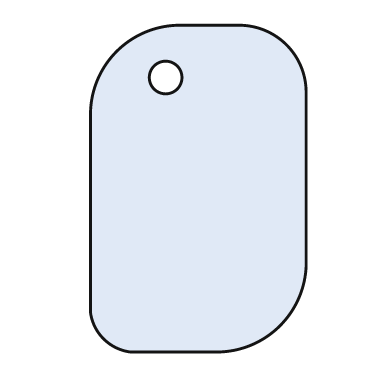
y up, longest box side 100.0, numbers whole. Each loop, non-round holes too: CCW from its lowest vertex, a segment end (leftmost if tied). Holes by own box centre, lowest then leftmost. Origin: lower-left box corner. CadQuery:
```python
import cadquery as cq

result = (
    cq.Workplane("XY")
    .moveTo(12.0, 0.0)
    .lineTo(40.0, 0.0)
    .threePointArc((58.0, 8.0), (66.0, 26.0))
    .lineTo(66.0, 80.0)
    .threePointArc((60.0, 94.0), (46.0, 100.0))
    .lineTo(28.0, 100.0)
    .threePointArc((8.0, 92.0), (0.0, 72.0))
    .lineTo(0.0, 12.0)
    .threePointArc((4.0, 4.0), (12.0, 0.0))
    .close()
    .moveTo(23.0, 84.0)
    .circle(5.0)
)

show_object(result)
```